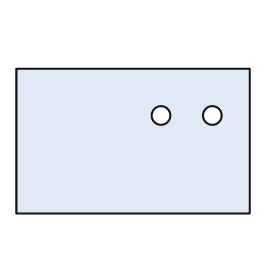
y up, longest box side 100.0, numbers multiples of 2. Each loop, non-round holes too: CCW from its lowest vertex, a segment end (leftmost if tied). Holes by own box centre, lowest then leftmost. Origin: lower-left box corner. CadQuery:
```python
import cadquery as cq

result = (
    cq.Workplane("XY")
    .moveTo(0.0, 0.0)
    .lineTo(100.0, 0.0)
    .lineTo(100.0, 62.0)
    .lineTo(0.0, 62.0)
    .close()
    .moveTo(62.0, 42.0)
    .circle(4.0)
    .moveTo(84.0, 42.0)
    .circle(4.0)
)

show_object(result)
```